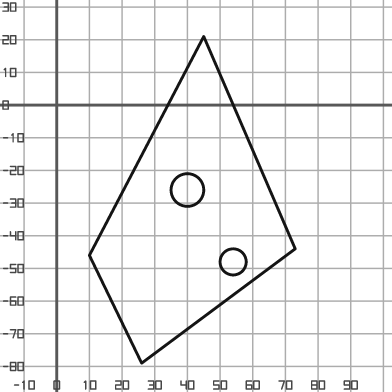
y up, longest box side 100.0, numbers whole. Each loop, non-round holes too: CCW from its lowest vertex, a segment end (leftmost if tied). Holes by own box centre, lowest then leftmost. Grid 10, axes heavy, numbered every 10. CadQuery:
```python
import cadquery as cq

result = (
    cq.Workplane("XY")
    .moveTo(26.0, -79.0)
    .lineTo(73.0, -44.0)
    .lineTo(45.0, 21.0)
    .lineTo(10.0, -46.0)
    .close()
    .moveTo(54.0, -48.0)
    .circle(4.0)
    .moveTo(40.0, -26.0)
    .circle(5.0)
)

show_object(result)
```